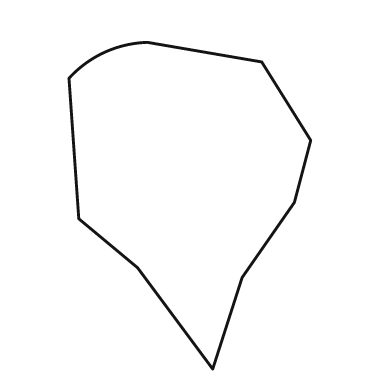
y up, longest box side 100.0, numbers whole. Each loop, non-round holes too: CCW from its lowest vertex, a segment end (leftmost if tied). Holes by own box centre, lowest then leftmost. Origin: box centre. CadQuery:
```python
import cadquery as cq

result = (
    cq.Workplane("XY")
    .moveTo(7.0, -50.0)
    .lineTo(16.0, -22.0)
    .lineTo(32.0, 1.0)
    .lineTo(37.0, 20.0)
    .lineTo(22.0, 44.0)
    .lineTo(-13.0, 50.0)
    .threePointArc((-26.0, 47.0), (-37.0, 39.0))
    .lineTo(-34.0, -4.0)
    .lineTo(-16.0, -19.0)
    .close()
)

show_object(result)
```